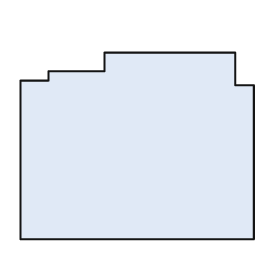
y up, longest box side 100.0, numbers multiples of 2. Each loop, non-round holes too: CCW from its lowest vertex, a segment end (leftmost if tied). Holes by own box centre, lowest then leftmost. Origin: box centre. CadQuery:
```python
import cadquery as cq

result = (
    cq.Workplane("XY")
    .moveTo(-50.0, -40.0)
    .lineTo(50.0, -40.0)
    .lineTo(50.0, 26.0)
    .lineTo(42.0, 26.0)
    .lineTo(42.0, 40.0)
    .lineTo(-14.0, 40.0)
    .lineTo(-14.0, 32.0)
    .lineTo(-38.0, 32.0)
    .lineTo(-38.0, 28.0)
    .lineTo(-50.0, 28.0)
    .close()
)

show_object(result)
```